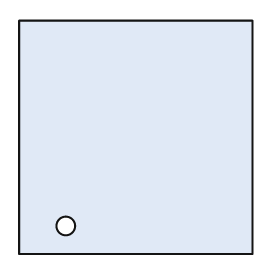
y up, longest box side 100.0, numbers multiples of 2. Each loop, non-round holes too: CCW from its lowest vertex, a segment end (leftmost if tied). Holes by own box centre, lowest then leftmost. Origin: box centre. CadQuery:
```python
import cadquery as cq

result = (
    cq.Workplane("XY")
    .moveTo(-50.0, -50.0)
    .lineTo(50.0, -50.0)
    .lineTo(50.0, 50.0)
    .lineTo(-50.0, 50.0)
    .close()
    .moveTo(-30.0, -38.0)
    .circle(4.0)
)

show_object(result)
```